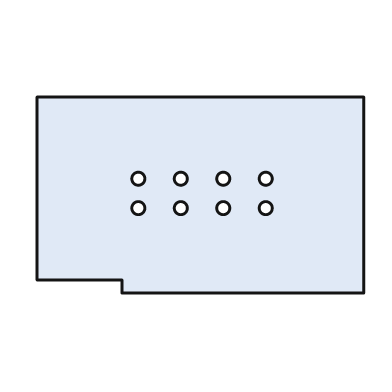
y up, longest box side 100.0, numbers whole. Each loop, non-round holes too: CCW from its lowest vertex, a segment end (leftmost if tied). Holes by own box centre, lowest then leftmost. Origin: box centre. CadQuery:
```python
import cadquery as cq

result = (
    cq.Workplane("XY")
    .moveTo(-24.0, -30.0)
    .lineTo(50.0, -30.0)
    .lineTo(50.0, 30.0)
    .lineTo(-50.0, 30.0)
    .lineTo(-50.0, -26.0)
    .lineTo(-24.0, -26.0)
    .close()
    .moveTo(-19.0, -4.0)
    .circle(2.0)
    .moveTo(-6.0, -4.0)
    .circle(2.0)
    .moveTo(7.0, -4.0)
    .circle(2.0)
    .moveTo(20.0, -4.0)
    .circle(2.0)
    .moveTo(-19.0, 5.0)
    .circle(2.0)
    .moveTo(-6.0, 5.0)
    .circle(2.0)
    .moveTo(7.0, 5.0)
    .circle(2.0)
    .moveTo(20.0, 5.0)
    .circle(2.0)
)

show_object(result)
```